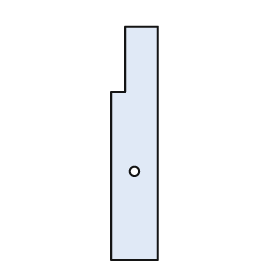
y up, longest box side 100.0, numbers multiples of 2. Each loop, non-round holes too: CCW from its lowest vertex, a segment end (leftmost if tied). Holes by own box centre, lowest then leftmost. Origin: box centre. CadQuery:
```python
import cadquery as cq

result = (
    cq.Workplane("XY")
    .moveTo(-10.0, -50.0)
    .lineTo(10.0, -50.0)
    .lineTo(10.0, 50.0)
    .lineTo(-4.0, 50.0)
    .lineTo(-4.0, 22.0)
    .lineTo(-10.0, 22.0)
    .close()
    .moveTo(0.0, -12.0)
    .circle(2.0)
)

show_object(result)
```